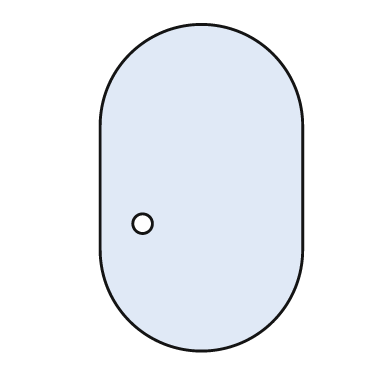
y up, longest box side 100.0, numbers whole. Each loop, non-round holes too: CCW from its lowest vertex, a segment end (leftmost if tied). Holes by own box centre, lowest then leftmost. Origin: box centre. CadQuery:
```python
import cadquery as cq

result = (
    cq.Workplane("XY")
    .moveTo(-31.0, -19.0)
    .threePointArc((0.0, -50.0), (31.0, -19.0))
    .lineTo(31.0, 19.0)
    .threePointArc((0.0, 50.0), (-31.0, 19.0))
    .close()
    .moveTo(-18.0, -11.0)
    .circle(3.0)
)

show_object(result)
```